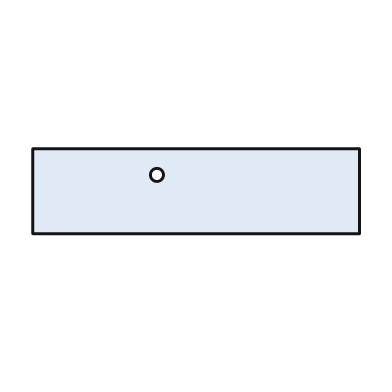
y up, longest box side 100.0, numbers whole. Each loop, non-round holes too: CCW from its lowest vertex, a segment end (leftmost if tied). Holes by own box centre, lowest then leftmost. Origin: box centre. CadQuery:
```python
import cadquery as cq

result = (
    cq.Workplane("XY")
    .moveTo(-50.0, -13.0)
    .lineTo(50.0, -13.0)
    .lineTo(50.0, 13.0)
    .lineTo(-50.0, 13.0)
    .close()
    .moveTo(-12.0, 5.0)
    .circle(2.0)
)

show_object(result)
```